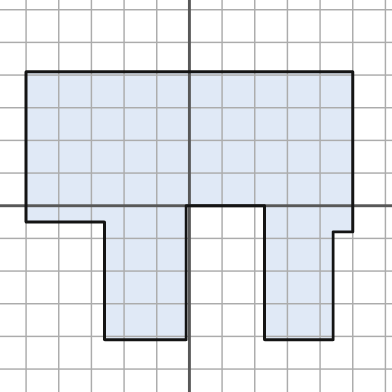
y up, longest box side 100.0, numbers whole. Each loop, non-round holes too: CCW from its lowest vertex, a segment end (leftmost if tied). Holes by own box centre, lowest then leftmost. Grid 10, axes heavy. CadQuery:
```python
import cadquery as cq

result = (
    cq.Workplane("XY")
    .moveTo(-26.0, -41.0)
    .lineTo(-1.0, -41.0)
    .lineTo(-1.0, 0.0)
    .lineTo(23.0, 0.0)
    .lineTo(23.0, -41.0)
    .lineTo(44.0, -41.0)
    .lineTo(44.0, -8.0)
    .lineTo(50.0, -8.0)
    .lineTo(50.0, 41.0)
    .lineTo(-50.0, 41.0)
    .lineTo(-50.0, -5.0)
    .lineTo(-26.0, -5.0)
    .close()
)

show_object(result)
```